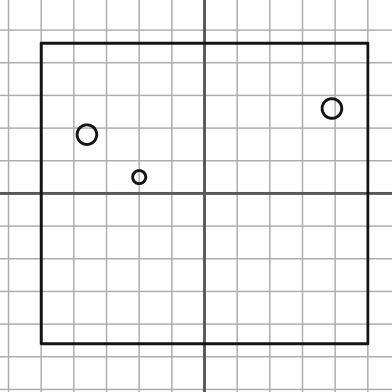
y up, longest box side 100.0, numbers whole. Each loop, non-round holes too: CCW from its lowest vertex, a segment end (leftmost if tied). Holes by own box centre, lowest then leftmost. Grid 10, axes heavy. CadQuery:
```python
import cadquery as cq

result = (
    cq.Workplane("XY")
    .moveTo(-50.0, -46.0)
    .lineTo(50.0, -46.0)
    .lineTo(50.0, 46.0)
    .lineTo(-50.0, 46.0)
    .close()
    .moveTo(-20.0, 5.0)
    .circle(2.0)
    .moveTo(-36.0, 18.0)
    .circle(3.0)
    .moveTo(39.0, 26.0)
    .circle(3.0)
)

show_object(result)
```